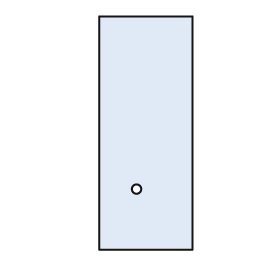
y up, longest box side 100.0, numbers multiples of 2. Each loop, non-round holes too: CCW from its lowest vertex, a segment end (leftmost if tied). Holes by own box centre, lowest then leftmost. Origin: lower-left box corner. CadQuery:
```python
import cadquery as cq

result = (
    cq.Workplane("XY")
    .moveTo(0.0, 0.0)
    .lineTo(40.0, 0.0)
    .lineTo(40.0, 100.0)
    .lineTo(0.0, 100.0)
    .close()
    .moveTo(16.0, 26.0)
    .circle(2.0)
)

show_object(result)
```